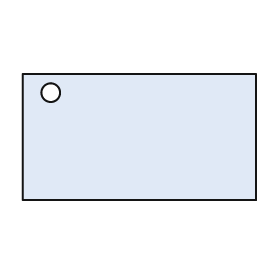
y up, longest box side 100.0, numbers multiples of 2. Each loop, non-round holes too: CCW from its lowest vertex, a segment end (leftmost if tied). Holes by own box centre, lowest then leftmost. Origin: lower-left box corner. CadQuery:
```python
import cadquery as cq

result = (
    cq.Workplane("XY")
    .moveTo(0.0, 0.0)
    .lineTo(100.0, 0.0)
    .lineTo(100.0, 54.0)
    .lineTo(0.0, 54.0)
    .close()
    .moveTo(12.0, 46.0)
    .circle(4.0)
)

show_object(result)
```